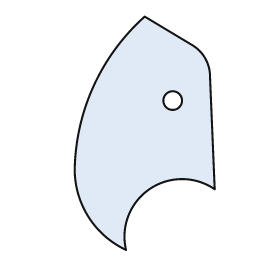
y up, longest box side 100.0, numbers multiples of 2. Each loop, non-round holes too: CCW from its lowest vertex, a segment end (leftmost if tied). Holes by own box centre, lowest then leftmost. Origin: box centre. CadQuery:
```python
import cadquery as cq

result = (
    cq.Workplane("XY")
    .moveTo(-8.0, -50.0)
    .threePointArc((2.0, -24.0), (30.0, -24.0))
    .lineTo(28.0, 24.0)
    .threePointArc((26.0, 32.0), (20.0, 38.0))
    .lineTo(0.0, 50.0)
    .threePointArc((-22.0, 20.0), (-30.0, -16.0))
    .threePointArc((-24.0, -36.0), (-8.0, -50.0))
    .close()
    .moveTo(12.0, 14.0)
    .circle(4.0)
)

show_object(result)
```